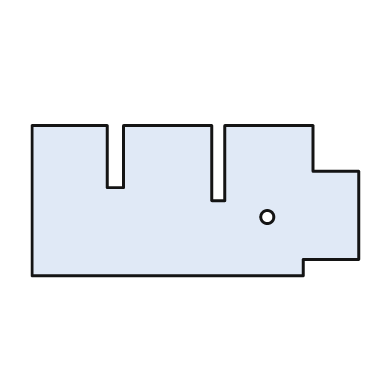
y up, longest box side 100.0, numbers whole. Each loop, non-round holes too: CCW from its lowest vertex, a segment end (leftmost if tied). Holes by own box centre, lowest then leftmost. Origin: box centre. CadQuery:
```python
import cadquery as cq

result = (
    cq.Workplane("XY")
    .moveTo(-50.0, -23.0)
    .lineTo(33.0, -23.0)
    .lineTo(33.0, -18.0)
    .lineTo(50.0, -18.0)
    .lineTo(50.0, 9.0)
    .lineTo(36.0, 9.0)
    .lineTo(36.0, 23.0)
    .lineTo(9.0, 23.0)
    .lineTo(9.0, 0.0)
    .lineTo(5.0, 0.0)
    .lineTo(5.0, 23.0)
    .lineTo(-22.0, 23.0)
    .lineTo(-22.0, 4.0)
    .lineTo(-27.0, 4.0)
    .lineTo(-27.0, 23.0)
    .lineTo(-50.0, 23.0)
    .close()
    .moveTo(22.0, -5.0)
    .circle(2.0)
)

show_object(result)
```